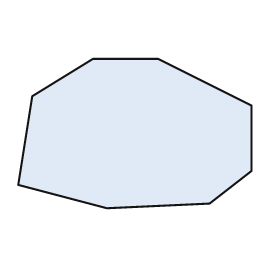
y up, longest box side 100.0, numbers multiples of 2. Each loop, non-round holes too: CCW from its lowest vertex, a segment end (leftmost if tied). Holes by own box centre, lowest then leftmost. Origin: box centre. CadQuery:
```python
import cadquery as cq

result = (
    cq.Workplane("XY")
    .moveTo(-12.0, -32.0)
    .lineTo(32.0, -30.0)
    .lineTo(50.0, -16.0)
    .lineTo(50.0, 12.0)
    .lineTo(10.0, 32.0)
    .lineTo(-18.0, 32.0)
    .lineTo(-44.0, 16.0)
    .lineTo(-50.0, -22.0)
    .close()
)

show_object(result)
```